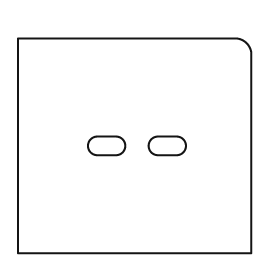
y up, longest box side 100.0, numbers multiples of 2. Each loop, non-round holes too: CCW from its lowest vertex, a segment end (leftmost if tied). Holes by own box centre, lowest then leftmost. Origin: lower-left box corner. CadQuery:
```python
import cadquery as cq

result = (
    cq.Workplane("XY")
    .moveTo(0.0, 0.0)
    .lineTo(100.0, 0.0)
    .lineTo(100.0, 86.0)
    .threePointArc((98.0, 90.0), (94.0, 92.0))
    .lineTo(0.0, 92.0)
    .close()
    .moveTo(34.0, 42.0)
    .lineTo(42.0, 42.0)
    .threePointArc((46.0, 46.0), (42.0, 50.0))
    .lineTo(34.0, 50.0)
    .threePointArc((30.0, 46.0), (34.0, 42.0))
    .close()
    .moveTo(60.0, 42.0)
    .lineTo(68.0, 42.0)
    .threePointArc((72.0, 46.0), (68.0, 50.0))
    .lineTo(60.0, 50.0)
    .threePointArc((56.0, 46.0), (60.0, 42.0))
    .close()
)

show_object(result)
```